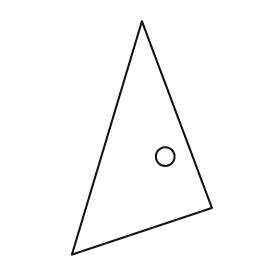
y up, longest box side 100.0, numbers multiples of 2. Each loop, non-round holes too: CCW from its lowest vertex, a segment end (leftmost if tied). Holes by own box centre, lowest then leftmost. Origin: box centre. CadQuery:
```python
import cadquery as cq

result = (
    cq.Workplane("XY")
    .moveTo(-30.0, -50.0)
    .lineTo(30.0, -30.0)
    .lineTo(0.0, 50.0)
    .close()
    .moveTo(10.0, -8.0)
    .circle(4.0)
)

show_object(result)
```